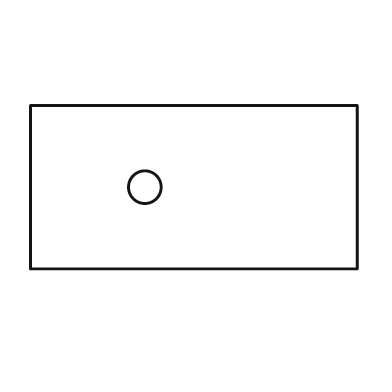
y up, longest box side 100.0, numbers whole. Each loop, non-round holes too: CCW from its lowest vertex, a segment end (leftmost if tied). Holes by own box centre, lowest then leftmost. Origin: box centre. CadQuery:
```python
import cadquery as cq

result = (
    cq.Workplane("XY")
    .moveTo(-50.0, -25.0)
    .lineTo(50.0, -25.0)
    .lineTo(50.0, 25.0)
    .lineTo(-50.0, 25.0)
    .close()
    .moveTo(-15.0, 0.0)
    .circle(5.0)
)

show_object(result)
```